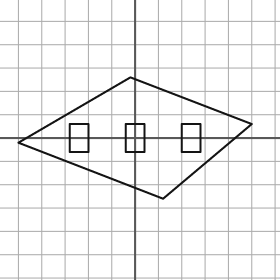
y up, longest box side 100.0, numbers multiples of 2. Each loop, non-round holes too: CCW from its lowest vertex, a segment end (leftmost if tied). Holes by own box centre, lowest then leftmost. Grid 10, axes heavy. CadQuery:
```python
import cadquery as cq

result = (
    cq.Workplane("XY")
    .moveTo(12.0, -26.0)
    .lineTo(50.0, 6.0)
    .lineTo(-2.0, 26.0)
    .lineTo(-50.0, -2.0)
    .close()
    .moveTo(-28.0, -6.0)
    .lineTo(-20.0, -6.0)
    .lineTo(-20.0, 6.0)
    .lineTo(-28.0, 6.0)
    .close()
    .moveTo(-4.0, -6.0)
    .lineTo(4.0, -6.0)
    .lineTo(4.0, 6.0)
    .lineTo(-4.0, 6.0)
    .close()
    .moveTo(20.0, -6.0)
    .lineTo(28.0, -6.0)
    .lineTo(28.0, 6.0)
    .lineTo(20.0, 6.0)
    .close()
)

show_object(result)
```